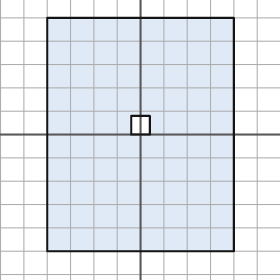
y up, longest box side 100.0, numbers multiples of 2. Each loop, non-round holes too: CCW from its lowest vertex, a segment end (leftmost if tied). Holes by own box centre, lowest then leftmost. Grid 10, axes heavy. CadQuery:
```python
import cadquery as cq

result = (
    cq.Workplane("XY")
    .moveTo(-40.0, -50.0)
    .lineTo(40.0, -50.0)
    .lineTo(40.0, 50.0)
    .lineTo(-40.0, 50.0)
    .close()
    .moveTo(-4.0, 0.0)
    .lineTo(4.0, 0.0)
    .lineTo(4.0, 8.0)
    .lineTo(-4.0, 8.0)
    .close()
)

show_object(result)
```